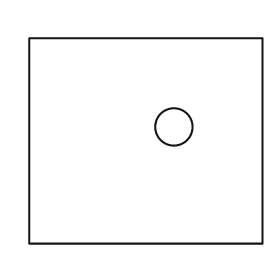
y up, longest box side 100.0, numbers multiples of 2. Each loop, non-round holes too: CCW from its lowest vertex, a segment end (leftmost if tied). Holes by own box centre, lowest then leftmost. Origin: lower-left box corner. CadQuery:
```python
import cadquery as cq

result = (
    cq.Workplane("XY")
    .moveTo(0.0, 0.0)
    .lineTo(100.0, 0.0)
    .lineTo(100.0, 88.0)
    .lineTo(0.0, 88.0)
    .close()
    .moveTo(62.0, 50.0)
    .circle(8.0)
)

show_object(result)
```